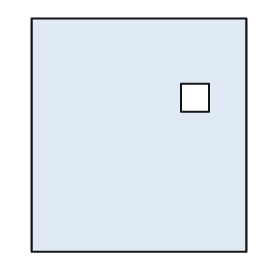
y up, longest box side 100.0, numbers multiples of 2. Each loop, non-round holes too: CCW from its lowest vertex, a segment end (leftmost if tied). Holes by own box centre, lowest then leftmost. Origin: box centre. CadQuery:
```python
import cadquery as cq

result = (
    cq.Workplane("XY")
    .moveTo(-46.0, -50.0)
    .lineTo(46.0, -50.0)
    .lineTo(46.0, 50.0)
    .lineTo(-46.0, 50.0)
    .close()
    .moveTo(18.0, 10.0)
    .lineTo(30.0, 10.0)
    .lineTo(30.0, 22.0)
    .lineTo(18.0, 22.0)
    .close()
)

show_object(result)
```